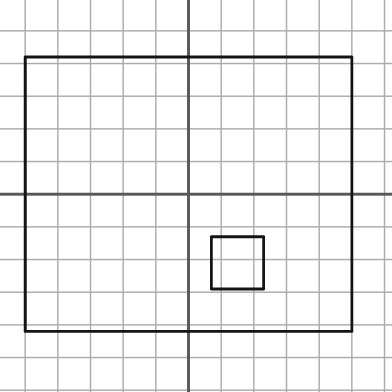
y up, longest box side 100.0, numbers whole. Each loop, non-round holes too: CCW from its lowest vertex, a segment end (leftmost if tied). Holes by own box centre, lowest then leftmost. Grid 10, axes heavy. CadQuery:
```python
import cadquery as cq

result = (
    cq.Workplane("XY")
    .moveTo(-50.0, -42.0)
    .lineTo(50.0, -42.0)
    .lineTo(50.0, 42.0)
    .lineTo(-50.0, 42.0)
    .close()
    .moveTo(7.0, -29.0)
    .lineTo(23.0, -29.0)
    .lineTo(23.0, -13.0)
    .lineTo(7.0, -13.0)
    .close()
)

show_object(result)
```